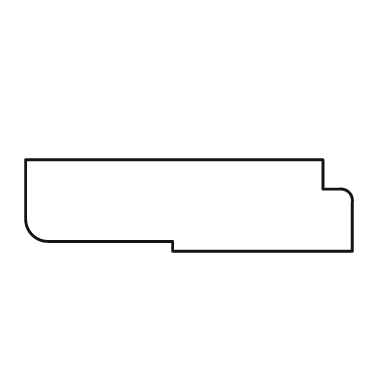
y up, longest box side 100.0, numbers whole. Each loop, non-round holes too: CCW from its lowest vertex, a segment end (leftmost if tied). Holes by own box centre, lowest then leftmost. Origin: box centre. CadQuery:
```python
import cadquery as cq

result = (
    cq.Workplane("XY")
    .moveTo(-5.0, -14.0)
    .lineTo(50.0, -14.0)
    .lineTo(50.0, 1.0)
    .threePointArc((49.0, 4.0), (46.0, 5.0))
    .lineTo(41.0, 5.0)
    .lineTo(41.0, 14.0)
    .lineTo(-50.0, 14.0)
    .lineTo(-50.0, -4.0)
    .threePointArc((-48.0, -9.0), (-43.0, -11.0))
    .lineTo(-5.0, -11.0)
    .close()
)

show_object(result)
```